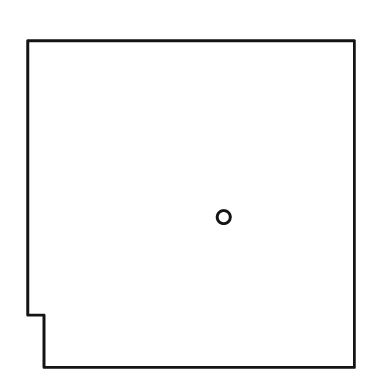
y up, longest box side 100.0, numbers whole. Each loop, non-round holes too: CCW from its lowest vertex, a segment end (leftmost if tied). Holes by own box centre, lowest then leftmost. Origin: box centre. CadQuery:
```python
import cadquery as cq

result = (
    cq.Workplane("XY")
    .moveTo(-45.0, -50.0)
    .lineTo(50.0, -50.0)
    .lineTo(50.0, 50.0)
    .lineTo(-50.0, 50.0)
    .lineTo(-50.0, -34.0)
    .lineTo(-45.0, -34.0)
    .close()
    .moveTo(10.0, -4.0)
    .circle(2.0)
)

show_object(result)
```